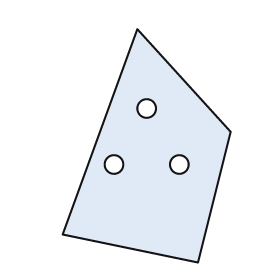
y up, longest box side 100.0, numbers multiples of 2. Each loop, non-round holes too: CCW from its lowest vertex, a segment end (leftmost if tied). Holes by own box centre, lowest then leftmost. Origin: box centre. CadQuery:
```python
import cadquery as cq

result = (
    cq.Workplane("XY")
    .moveTo(22.0, -50.0)
    .lineTo(36.0, 6.0)
    .lineTo(-4.0, 50.0)
    .lineTo(-36.0, -38.0)
    .close()
    .moveTo(-14.0, -8.0)
    .circle(4.0)
    .moveTo(14.0, -8.0)
    .circle(4.0)
    .moveTo(0.0, 16.0)
    .circle(4.0)
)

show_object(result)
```